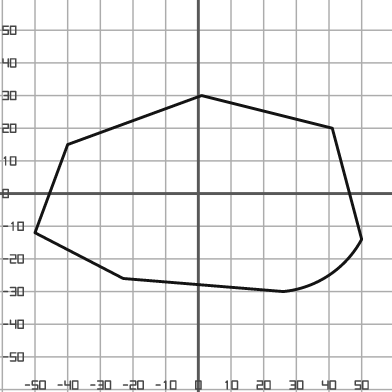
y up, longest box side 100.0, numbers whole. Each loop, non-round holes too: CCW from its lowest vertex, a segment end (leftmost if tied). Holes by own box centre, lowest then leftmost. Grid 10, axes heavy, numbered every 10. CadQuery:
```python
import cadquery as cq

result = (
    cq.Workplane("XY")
    .moveTo(26.0, -30.0)
    .threePointArc((40.0, -25.0), (50.0, -14.0))
    .lineTo(41.0, 20.0)
    .lineTo(1.0, 30.0)
    .lineTo(-40.0, 15.0)
    .lineTo(-50.0, -12.0)
    .lineTo(-23.0, -26.0)
    .close()
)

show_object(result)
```